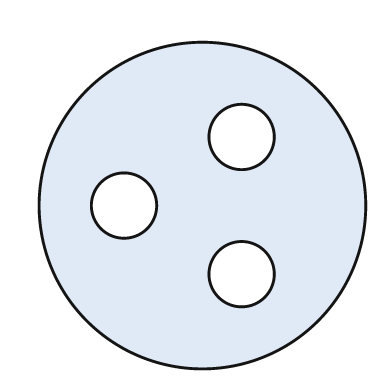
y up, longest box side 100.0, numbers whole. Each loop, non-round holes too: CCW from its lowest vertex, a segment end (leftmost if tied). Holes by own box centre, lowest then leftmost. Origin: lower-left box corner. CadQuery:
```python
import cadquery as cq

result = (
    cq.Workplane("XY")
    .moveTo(50.0, 50.0)
    .circle(50.0)
    .moveTo(62.0, 29.0)
    .circle(10.0)
    .moveTo(26.0, 50.0)
    .circle(10.0)
    .moveTo(62.0, 71.0)
    .circle(10.0)
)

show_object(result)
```